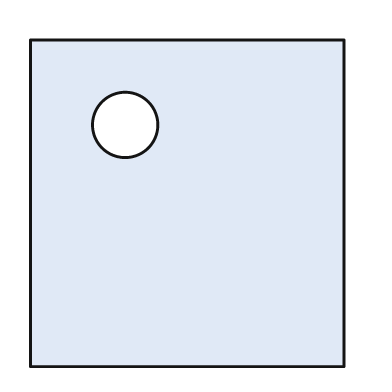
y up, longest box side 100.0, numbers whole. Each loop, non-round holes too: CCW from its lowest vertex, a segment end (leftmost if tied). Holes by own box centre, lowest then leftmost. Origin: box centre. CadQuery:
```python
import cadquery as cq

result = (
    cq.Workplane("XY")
    .moveTo(-48.0, -50.0)
    .lineTo(48.0, -50.0)
    .lineTo(48.0, 50.0)
    .lineTo(-48.0, 50.0)
    .close()
    .moveTo(-19.0, 24.0)
    .circle(10.0)
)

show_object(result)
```